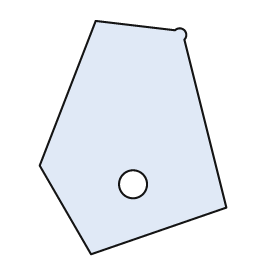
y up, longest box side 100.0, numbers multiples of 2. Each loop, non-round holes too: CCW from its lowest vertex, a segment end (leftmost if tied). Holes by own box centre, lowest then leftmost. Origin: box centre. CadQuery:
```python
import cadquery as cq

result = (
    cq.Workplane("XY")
    .moveTo(-18.0, -50.0)
    .lineTo(40.0, -30.0)
    .lineTo(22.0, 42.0)
    .threePointArc((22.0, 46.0), (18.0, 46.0))
    .lineTo(-16.0, 50.0)
    .lineTo(-40.0, -12.0)
    .close()
    .moveTo(0.0, -20.0)
    .circle(6.0)
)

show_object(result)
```